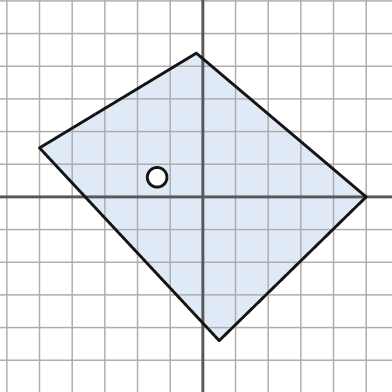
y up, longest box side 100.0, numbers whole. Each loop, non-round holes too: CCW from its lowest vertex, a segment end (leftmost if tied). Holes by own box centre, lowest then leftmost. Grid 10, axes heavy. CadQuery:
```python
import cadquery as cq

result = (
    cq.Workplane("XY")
    .moveTo(5.0, -44.0)
    .lineTo(50.0, 0.0)
    .lineTo(-2.0, 44.0)
    .lineTo(-50.0, 15.0)
    .close()
    .moveTo(-14.0, 6.0)
    .circle(3.0)
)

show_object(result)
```